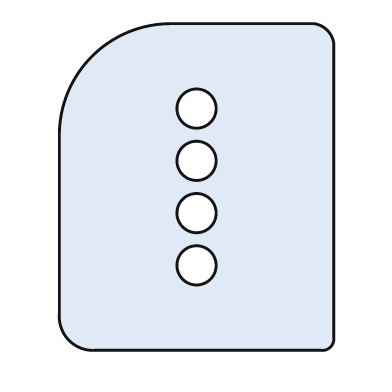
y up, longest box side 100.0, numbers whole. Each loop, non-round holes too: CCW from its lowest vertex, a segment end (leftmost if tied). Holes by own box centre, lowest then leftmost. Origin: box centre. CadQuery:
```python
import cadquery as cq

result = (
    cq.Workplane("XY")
    .moveTo(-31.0, -50.0)
    .lineTo(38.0, -50.0)
    .threePointArc((41.0, -49.0), (42.0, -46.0))
    .lineTo(42.0, 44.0)
    .threePointArc((40.0, 48.0), (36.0, 50.0))
    .lineTo(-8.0, 50.0)
    .threePointArc((-32.0, 40.0), (-42.0, 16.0))
    .lineTo(-42.0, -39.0)
    .threePointArc((-39.0, -47.0), (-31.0, -50.0))
    .close()
    .moveTo(0.0, -24.0)
    .circle(6.0)
    .moveTo(0.0, -8.0)
    .circle(6.0)
    .moveTo(0.0, 8.0)
    .circle(6.0)
    .moveTo(0.0, 24.0)
    .circle(6.0)
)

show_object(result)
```